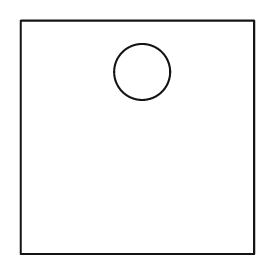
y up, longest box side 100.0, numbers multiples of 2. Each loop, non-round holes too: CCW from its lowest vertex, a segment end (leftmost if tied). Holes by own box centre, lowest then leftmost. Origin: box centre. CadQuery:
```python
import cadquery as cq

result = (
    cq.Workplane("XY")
    .moveTo(-50.0, -50.0)
    .lineTo(50.0, -50.0)
    .lineTo(50.0, 50.0)
    .lineTo(-50.0, 50.0)
    .close()
    .moveTo(2.0, 28.0)
    .circle(12.0)
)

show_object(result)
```